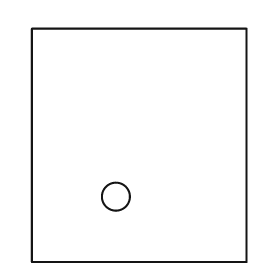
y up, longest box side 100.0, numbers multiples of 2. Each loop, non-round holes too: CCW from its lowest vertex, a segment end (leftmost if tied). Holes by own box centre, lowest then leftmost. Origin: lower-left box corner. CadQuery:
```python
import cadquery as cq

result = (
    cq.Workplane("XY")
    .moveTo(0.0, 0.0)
    .lineTo(92.0, 0.0)
    .lineTo(92.0, 100.0)
    .lineTo(0.0, 100.0)
    .close()
    .moveTo(36.0, 28.0)
    .circle(6.0)
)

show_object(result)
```